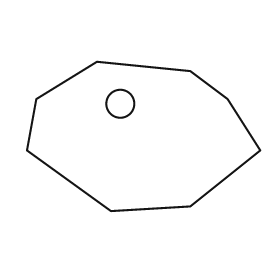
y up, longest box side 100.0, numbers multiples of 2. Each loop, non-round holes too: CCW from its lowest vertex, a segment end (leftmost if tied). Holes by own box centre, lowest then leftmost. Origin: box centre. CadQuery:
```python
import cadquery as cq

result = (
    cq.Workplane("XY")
    .moveTo(-14.0, -32.0)
    .lineTo(20.0, -30.0)
    .lineTo(50.0, -6.0)
    .lineTo(36.0, 16.0)
    .lineTo(20.0, 28.0)
    .lineTo(-20.0, 32.0)
    .lineTo(-46.0, 16.0)
    .lineTo(-50.0, -6.0)
    .close()
    .moveTo(-10.0, 14.0)
    .circle(6.0)
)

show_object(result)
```